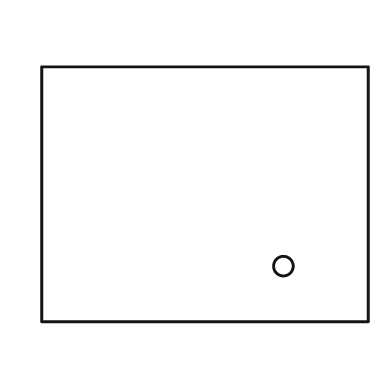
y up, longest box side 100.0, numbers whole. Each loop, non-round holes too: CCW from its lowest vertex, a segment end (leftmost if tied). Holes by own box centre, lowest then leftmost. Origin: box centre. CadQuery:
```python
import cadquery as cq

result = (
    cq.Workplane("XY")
    .moveTo(-50.0, -39.0)
    .lineTo(50.0, -39.0)
    .lineTo(50.0, 39.0)
    .lineTo(-50.0, 39.0)
    .close()
    .moveTo(24.0, -22.0)
    .circle(3.0)
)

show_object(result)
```